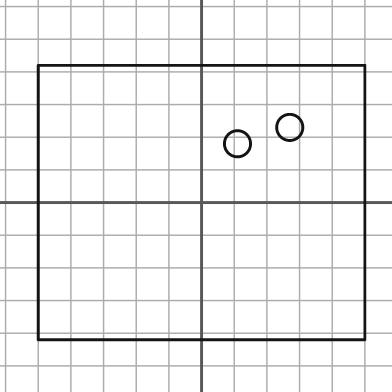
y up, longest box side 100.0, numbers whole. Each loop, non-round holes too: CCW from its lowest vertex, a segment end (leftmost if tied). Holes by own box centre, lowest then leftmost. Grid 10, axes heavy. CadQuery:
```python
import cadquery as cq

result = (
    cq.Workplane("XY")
    .moveTo(-50.0, -42.0)
    .lineTo(50.0, -42.0)
    .lineTo(50.0, 42.0)
    .lineTo(-50.0, 42.0)
    .close()
    .moveTo(11.0, 18.0)
    .circle(4.0)
    .moveTo(27.0, 23.0)
    .circle(4.0)
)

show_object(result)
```